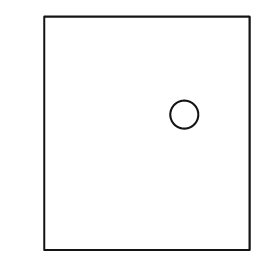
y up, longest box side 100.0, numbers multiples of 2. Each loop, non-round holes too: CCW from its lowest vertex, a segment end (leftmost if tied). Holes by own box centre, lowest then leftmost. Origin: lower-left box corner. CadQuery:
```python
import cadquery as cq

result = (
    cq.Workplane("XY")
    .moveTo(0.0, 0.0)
    .lineTo(88.0, 0.0)
    .lineTo(88.0, 100.0)
    .lineTo(0.0, 100.0)
    .close()
    .moveTo(60.0, 58.0)
    .circle(6.0)
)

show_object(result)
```